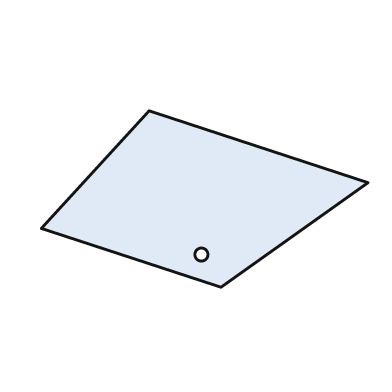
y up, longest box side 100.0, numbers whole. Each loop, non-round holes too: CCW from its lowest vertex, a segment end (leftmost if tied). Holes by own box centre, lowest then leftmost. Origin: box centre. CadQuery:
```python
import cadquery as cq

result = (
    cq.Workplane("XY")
    .moveTo(5.0, -27.0)
    .lineTo(50.0, 5.0)
    .lineTo(-17.0, 27.0)
    .lineTo(-50.0, -9.0)
    .close()
    .moveTo(-1.0, -17.0)
    .circle(2.0)
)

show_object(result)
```